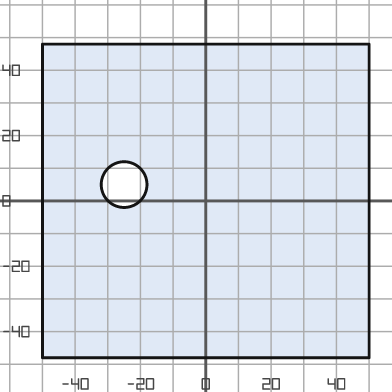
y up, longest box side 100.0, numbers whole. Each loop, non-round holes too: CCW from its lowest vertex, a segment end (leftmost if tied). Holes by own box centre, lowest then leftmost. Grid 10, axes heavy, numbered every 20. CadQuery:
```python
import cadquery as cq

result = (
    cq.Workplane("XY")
    .moveTo(-50.0, -48.0)
    .lineTo(50.0, -48.0)
    .lineTo(50.0, 48.0)
    .lineTo(-50.0, 48.0)
    .close()
    .moveTo(-25.0, 5.0)
    .circle(7.0)
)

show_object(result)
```